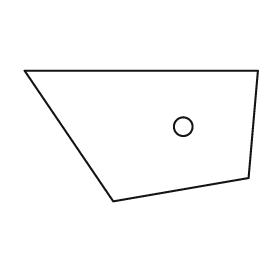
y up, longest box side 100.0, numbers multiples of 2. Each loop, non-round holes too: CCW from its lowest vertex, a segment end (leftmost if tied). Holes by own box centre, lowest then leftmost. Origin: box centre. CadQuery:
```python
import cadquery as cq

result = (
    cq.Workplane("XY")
    .moveTo(-12.0, -28.0)
    .lineTo(46.0, -18.0)
    .lineTo(50.0, 28.0)
    .lineTo(-50.0, 28.0)
    .close()
    .moveTo(18.0, 4.0)
    .circle(4.0)
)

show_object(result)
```